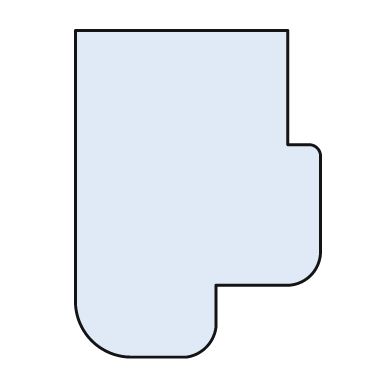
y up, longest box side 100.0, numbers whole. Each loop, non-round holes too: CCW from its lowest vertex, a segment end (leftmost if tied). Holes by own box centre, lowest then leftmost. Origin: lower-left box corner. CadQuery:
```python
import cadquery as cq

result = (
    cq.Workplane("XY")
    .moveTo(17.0, 0.0)
    .lineTo(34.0, 0.0)
    .threePointArc((40.0, 3.0), (43.0, 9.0))
    .lineTo(43.0, 22.0)
    .lineTo(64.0, 22.0)
    .threePointArc((72.0, 25.0), (75.0, 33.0))
    .lineTo(75.0, 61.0)
    .threePointArc((74.0, 64.0), (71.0, 65.0))
    .lineTo(65.0, 65.0)
    .lineTo(65.0, 100.0)
    .lineTo(0.0, 100.0)
    .lineTo(0.0, 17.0)
    .threePointArc((5.0, 5.0), (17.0, 0.0))
    .close()
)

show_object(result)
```